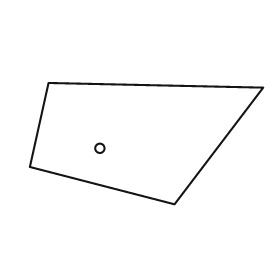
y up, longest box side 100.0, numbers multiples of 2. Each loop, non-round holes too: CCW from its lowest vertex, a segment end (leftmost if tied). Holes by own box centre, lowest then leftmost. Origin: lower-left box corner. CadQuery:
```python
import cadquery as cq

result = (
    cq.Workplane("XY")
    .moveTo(62.0, 0.0)
    .lineTo(100.0, 50.0)
    .lineTo(8.0, 52.0)
    .lineTo(0.0, 16.0)
    .close()
    .moveTo(30.0, 24.0)
    .circle(2.0)
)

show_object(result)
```